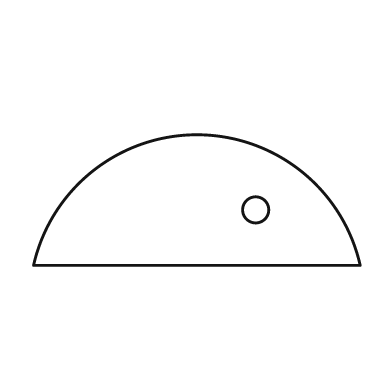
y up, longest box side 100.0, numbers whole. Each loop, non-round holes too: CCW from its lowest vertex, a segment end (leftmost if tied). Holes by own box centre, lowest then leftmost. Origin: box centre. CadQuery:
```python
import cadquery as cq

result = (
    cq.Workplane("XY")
    .moveTo(-50.0, -20.0)
    .lineTo(50.0, -20.0)
    .threePointArc((0.0, 20.0), (-50.0, -20.0))
    .close()
    .moveTo(18.0, -3.0)
    .circle(4.0)
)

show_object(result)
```